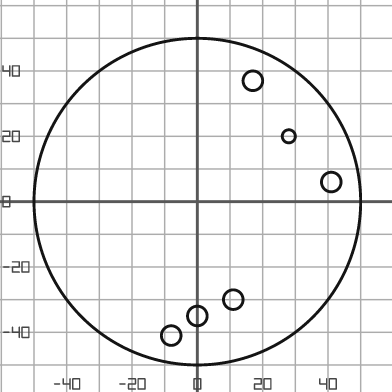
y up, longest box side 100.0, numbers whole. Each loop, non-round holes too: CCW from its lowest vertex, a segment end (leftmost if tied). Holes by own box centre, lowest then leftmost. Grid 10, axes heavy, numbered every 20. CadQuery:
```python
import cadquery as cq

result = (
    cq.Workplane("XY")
    .moveTo(0.0, 0.0)
    .circle(50.0)
    .moveTo(-8.0, -41.0)
    .circle(3.0)
    .moveTo(0.0, -35.0)
    .circle(3.0)
    .moveTo(11.0, -30.0)
    .circle(3.0)
    .moveTo(41.0, 6.0)
    .circle(3.0)
    .moveTo(28.0, 20.0)
    .circle(2.0)
    .moveTo(17.0, 37.0)
    .circle(3.0)
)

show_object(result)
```